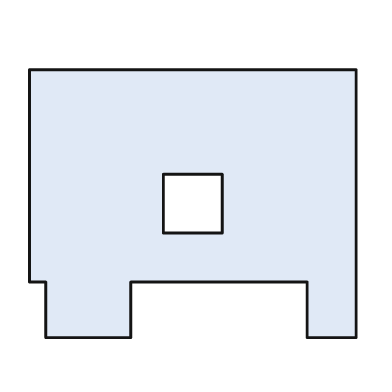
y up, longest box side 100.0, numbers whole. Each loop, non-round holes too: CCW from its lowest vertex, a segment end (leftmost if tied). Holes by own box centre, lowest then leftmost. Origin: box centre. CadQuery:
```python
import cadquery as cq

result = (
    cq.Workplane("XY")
    .moveTo(-45.0, -41.0)
    .lineTo(-19.0, -41.0)
    .lineTo(-19.0, -24.0)
    .lineTo(35.0, -24.0)
    .lineTo(35.0, -41.0)
    .lineTo(50.0, -41.0)
    .lineTo(50.0, 41.0)
    .lineTo(-50.0, 41.0)
    .lineTo(-50.0, -24.0)
    .lineTo(-45.0, -24.0)
    .close()
    .moveTo(-9.0, -9.0)
    .lineTo(9.0, -9.0)
    .lineTo(9.0, 9.0)
    .lineTo(-9.0, 9.0)
    .close()
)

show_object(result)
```